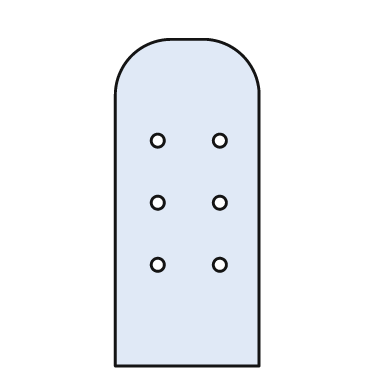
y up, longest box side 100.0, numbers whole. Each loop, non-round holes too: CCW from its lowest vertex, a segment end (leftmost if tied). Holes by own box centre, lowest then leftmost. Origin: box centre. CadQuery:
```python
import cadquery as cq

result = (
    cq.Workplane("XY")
    .moveTo(-22.0, -50.0)
    .lineTo(22.0, -50.0)
    .lineTo(22.0, 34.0)
    .threePointArc((17.0, 45.0), (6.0, 50.0))
    .lineTo(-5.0, 50.0)
    .threePointArc((-17.0, 45.0), (-22.0, 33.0))
    .close()
    .moveTo(-9.0, -19.0)
    .circle(2.0)
    .moveTo(10.0, -19.0)
    .circle(2.0)
    .moveTo(-9.0, 0.0)
    .circle(2.0)
    .moveTo(10.0, 0.0)
    .circle(2.0)
    .moveTo(-9.0, 19.0)
    .circle(2.0)
    .moveTo(10.0, 19.0)
    .circle(2.0)
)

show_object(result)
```